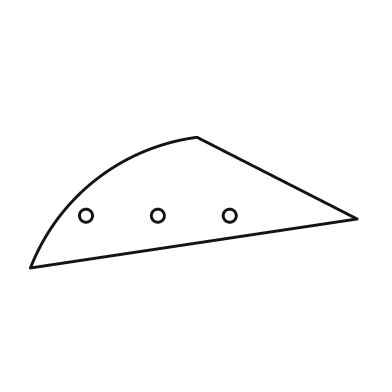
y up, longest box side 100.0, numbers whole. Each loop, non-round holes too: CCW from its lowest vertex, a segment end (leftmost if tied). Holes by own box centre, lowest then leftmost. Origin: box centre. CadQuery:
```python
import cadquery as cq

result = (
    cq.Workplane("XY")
    .moveTo(-50.0, -20.0)
    .lineTo(50.0, -5.0)
    .lineTo(1.0, 20.0)
    .threePointArc((-30.0, 7.0), (-50.0, -20.0))
    .close()
    .moveTo(-33.0, -4.0)
    .circle(2.0)
    .moveTo(-11.0, -4.0)
    .circle(2.0)
    .moveTo(11.0, -4.0)
    .circle(2.0)
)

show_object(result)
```